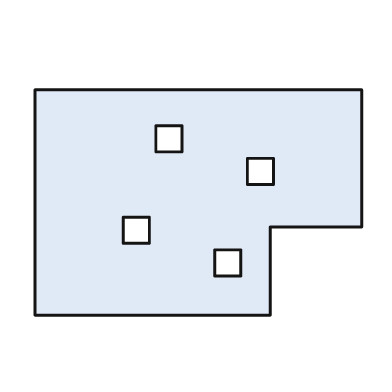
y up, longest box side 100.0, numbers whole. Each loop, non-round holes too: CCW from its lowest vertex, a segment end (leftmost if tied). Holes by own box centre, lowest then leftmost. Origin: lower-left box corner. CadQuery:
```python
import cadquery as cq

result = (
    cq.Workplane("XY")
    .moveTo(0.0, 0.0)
    .lineTo(72.0, 0.0)
    .lineTo(72.0, 27.0)
    .lineTo(100.0, 27.0)
    .lineTo(100.0, 69.0)
    .lineTo(0.0, 69.0)
    .close()
    .moveTo(55.0, 12.0)
    .lineTo(63.0, 12.0)
    .lineTo(63.0, 20.0)
    .lineTo(55.0, 20.0)
    .close()
    .moveTo(27.0, 22.0)
    .lineTo(35.0, 22.0)
    .lineTo(35.0, 30.0)
    .lineTo(27.0, 30.0)
    .close()
    .moveTo(65.0, 40.0)
    .lineTo(73.0, 40.0)
    .lineTo(73.0, 48.0)
    .lineTo(65.0, 48.0)
    .close()
    .moveTo(37.0, 50.0)
    .lineTo(45.0, 50.0)
    .lineTo(45.0, 58.0)
    .lineTo(37.0, 58.0)
    .close()
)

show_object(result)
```